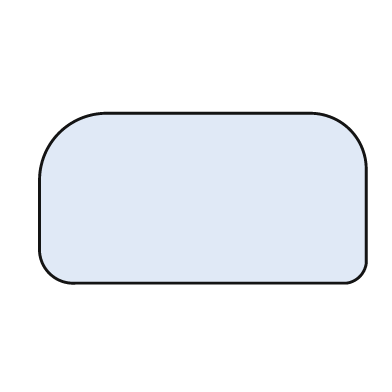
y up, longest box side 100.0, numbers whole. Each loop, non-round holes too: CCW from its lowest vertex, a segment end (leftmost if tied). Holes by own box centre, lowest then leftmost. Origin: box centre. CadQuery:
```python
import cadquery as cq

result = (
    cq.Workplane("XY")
    .moveTo(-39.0, -26.0)
    .lineTo(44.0, -26.0)
    .threePointArc((48.0, -24.0), (50.0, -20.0))
    .lineTo(50.0, 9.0)
    .threePointArc((45.0, 21.0), (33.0, 26.0))
    .lineTo(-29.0, 26.0)
    .threePointArc((-44.0, 20.0), (-50.0, 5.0))
    .lineTo(-50.0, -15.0)
    .threePointArc((-47.0, -23.0), (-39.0, -26.0))
    .close()
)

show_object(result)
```